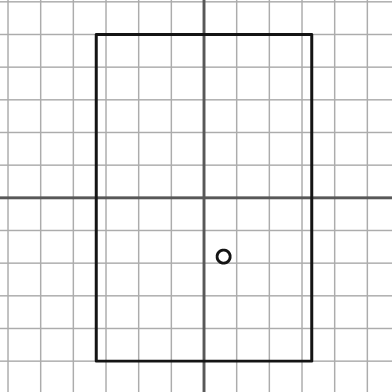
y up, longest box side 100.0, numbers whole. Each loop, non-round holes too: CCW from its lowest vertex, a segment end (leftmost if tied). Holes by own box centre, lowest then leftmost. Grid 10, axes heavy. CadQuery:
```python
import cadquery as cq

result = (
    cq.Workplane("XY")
    .moveTo(-33.0, -50.0)
    .lineTo(33.0, -50.0)
    .lineTo(33.0, 50.0)
    .lineTo(-33.0, 50.0)
    .close()
    .moveTo(6.0, -18.0)
    .circle(2.0)
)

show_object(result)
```